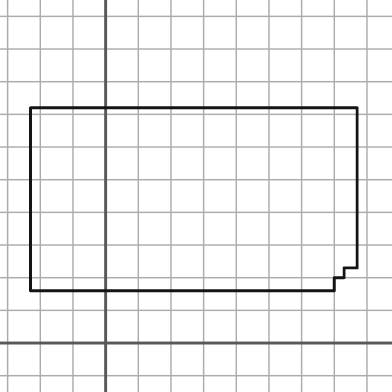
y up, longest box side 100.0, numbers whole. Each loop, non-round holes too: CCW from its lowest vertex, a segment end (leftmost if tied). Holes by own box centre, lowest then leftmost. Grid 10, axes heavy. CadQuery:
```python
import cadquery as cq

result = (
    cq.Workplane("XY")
    .moveTo(-23.0, 16.0)
    .lineTo(70.0, 16.0)
    .lineTo(70.0, 20.0)
    .lineTo(73.0, 20.0)
    .lineTo(73.0, 23.0)
    .lineTo(77.0, 23.0)
    .lineTo(77.0, 72.0)
    .lineTo(-23.0, 72.0)
    .close()
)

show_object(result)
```